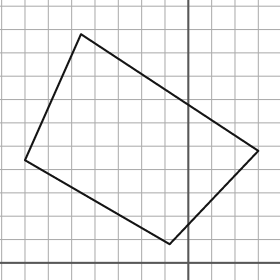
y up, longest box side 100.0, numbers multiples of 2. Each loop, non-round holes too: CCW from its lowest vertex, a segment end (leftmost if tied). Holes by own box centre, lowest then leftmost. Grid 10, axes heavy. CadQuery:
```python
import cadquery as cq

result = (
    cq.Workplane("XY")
    .moveTo(-8.0, 8.0)
    .lineTo(30.0, 48.0)
    .lineTo(-46.0, 98.0)
    .lineTo(-70.0, 44.0)
    .close()
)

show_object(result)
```